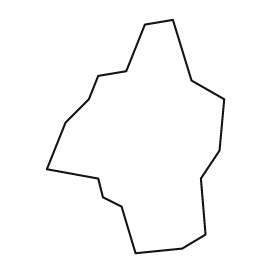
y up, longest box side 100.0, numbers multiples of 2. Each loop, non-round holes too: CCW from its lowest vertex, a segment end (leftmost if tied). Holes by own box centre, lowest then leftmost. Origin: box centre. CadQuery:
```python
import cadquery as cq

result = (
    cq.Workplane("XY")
    .moveTo(0.0, -50.0)
    .lineTo(20.0, -48.0)
    .lineTo(30.0, -42.0)
    .lineTo(28.0, -18.0)
    .lineTo(36.0, -6.0)
    .lineTo(38.0, 16.0)
    .lineTo(24.0, 24.0)
    .lineTo(16.0, 50.0)
    .lineTo(4.0, 48.0)
    .lineTo(-4.0, 28.0)
    .lineTo(-16.0, 26.0)
    .lineTo(-20.0, 16.0)
    .lineTo(-30.0, 6.0)
    .lineTo(-38.0, -14.0)
    .lineTo(-16.0, -18.0)
    .lineTo(-14.0, -26.0)
    .lineTo(-6.0, -30.0)
    .close()
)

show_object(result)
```